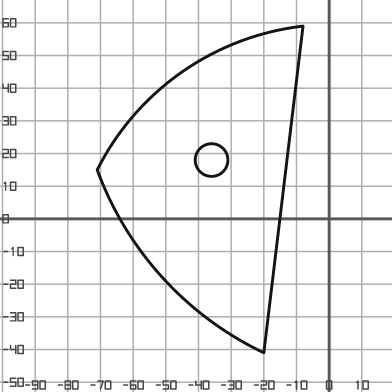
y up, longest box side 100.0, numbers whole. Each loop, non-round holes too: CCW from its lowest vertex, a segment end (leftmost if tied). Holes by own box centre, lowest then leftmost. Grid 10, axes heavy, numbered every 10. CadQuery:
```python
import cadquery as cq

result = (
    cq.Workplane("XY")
    .moveTo(-20.0, -41.0)
    .lineTo(-8.0, 59.0)
    .threePointArc((-45.0, 45.0), (-71.0, 15.0))
    .threePointArc((-51.0, -18.0), (-20.0, -41.0))
    .close()
    .moveTo(-36.0, 18.0)
    .circle(5.0)
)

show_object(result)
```